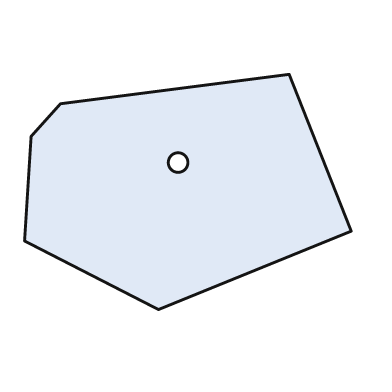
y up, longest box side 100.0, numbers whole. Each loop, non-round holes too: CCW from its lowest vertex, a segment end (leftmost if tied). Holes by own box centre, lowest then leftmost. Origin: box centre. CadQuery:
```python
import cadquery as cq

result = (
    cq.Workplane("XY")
    .moveTo(-9.0, -36.0)
    .lineTo(50.0, -12.0)
    .lineTo(31.0, 36.0)
    .lineTo(-39.0, 27.0)
    .lineTo(-48.0, 17.0)
    .lineTo(-50.0, -15.0)
    .close()
    .moveTo(-3.0, 9.0)
    .circle(3.0)
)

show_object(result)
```